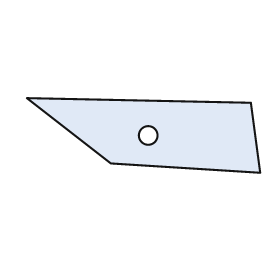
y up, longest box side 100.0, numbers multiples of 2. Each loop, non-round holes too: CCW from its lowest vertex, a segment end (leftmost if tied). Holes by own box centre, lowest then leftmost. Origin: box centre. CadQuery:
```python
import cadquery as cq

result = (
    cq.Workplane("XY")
    .moveTo(50.0, -16.0)
    .lineTo(46.0, 14.0)
    .lineTo(-50.0, 16.0)
    .lineTo(-14.0, -12.0)
    .close()
    .moveTo(2.0, 0.0)
    .circle(4.0)
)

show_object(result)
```